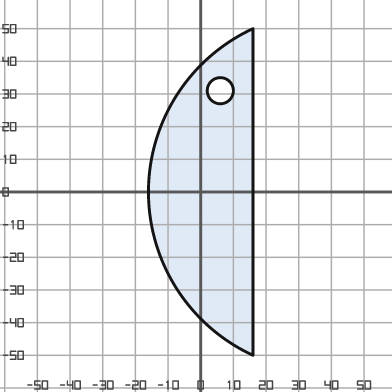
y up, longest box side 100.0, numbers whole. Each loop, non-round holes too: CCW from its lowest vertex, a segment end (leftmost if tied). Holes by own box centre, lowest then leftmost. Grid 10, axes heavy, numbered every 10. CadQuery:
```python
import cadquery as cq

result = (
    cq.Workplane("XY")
    .moveTo(16.0, -50.0)
    .lineTo(16.0, 50.0)
    .threePointArc((-16.0, 0.0), (16.0, -50.0))
    .close()
    .moveTo(6.0, 31.0)
    .circle(4.0)
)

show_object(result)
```